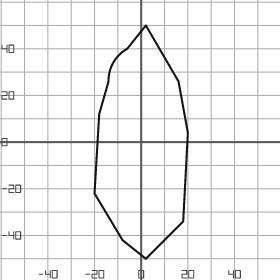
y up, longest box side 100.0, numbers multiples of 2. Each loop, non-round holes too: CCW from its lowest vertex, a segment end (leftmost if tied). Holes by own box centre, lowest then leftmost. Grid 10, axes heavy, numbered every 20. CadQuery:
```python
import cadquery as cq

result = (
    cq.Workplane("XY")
    .moveTo(2.0, -50.0)
    .lineTo(18.0, -34.0)
    .lineTo(20.0, 4.0)
    .lineTo(16.0, 26.0)
    .lineTo(2.0, 50.0)
    .lineTo(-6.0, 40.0)
    .threePointArc((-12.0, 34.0), (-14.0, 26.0))
    .lineTo(-18.0, 12.0)
    .lineTo(-20.0, -22.0)
    .lineTo(-8.0, -42.0)
    .close()
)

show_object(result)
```